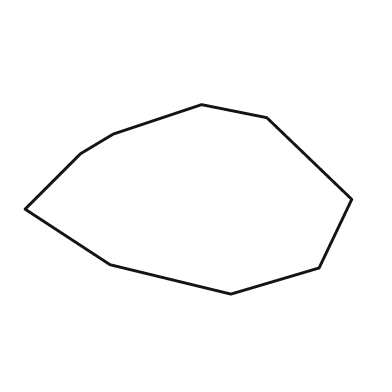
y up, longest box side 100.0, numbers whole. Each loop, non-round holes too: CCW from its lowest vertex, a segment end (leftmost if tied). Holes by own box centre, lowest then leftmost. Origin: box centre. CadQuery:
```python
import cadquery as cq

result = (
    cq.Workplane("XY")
    .moveTo(13.0, -29.0)
    .lineTo(40.0, -21.0)
    .lineTo(50.0, 0.0)
    .lineTo(24.0, 25.0)
    .lineTo(4.0, 29.0)
    .lineTo(-23.0, 20.0)
    .lineTo(-33.0, 14.0)
    .lineTo(-50.0, -3.0)
    .lineTo(-24.0, -20.0)
    .close()
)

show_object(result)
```